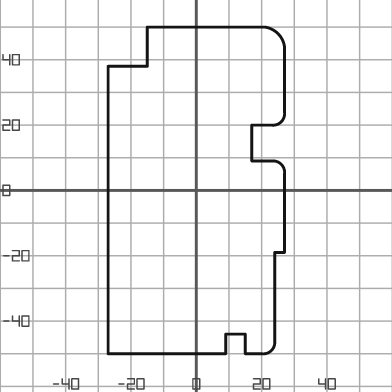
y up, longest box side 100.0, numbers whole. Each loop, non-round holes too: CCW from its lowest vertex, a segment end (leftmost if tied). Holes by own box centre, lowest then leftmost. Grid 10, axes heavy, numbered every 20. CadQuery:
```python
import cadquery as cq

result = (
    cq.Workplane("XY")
    .moveTo(-27.0, -50.0)
    .lineTo(9.0, -50.0)
    .lineTo(9.0, -44.0)
    .lineTo(15.0, -44.0)
    .lineTo(15.0, -50.0)
    .lineTo(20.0, -50.0)
    .threePointArc((23.0, -49.0), (24.0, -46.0))
    .lineTo(24.0, -19.0)
    .lineTo(27.0, -19.0)
    .lineTo(27.0, 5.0)
    .threePointArc((26.0, 8.0), (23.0, 9.0))
    .lineTo(17.0, 9.0)
    .lineTo(17.0, 20.0)
    .lineTo(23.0, 20.0)
    .threePointArc((26.0, 21.0), (27.0, 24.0))
    .lineTo(27.0, 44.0)
    .threePointArc((25.0, 48.0), (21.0, 50.0))
    .lineTo(-15.0, 50.0)
    .lineTo(-15.0, 38.0)
    .lineTo(-27.0, 38.0)
    .close()
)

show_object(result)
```